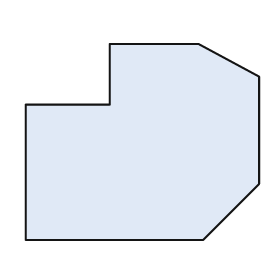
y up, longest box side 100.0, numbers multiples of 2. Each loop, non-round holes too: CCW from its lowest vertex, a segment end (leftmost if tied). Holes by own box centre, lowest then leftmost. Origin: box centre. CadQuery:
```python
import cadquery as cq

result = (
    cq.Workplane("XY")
    .moveTo(-50.0, -42.0)
    .lineTo(26.0, -42.0)
    .lineTo(50.0, -18.0)
    .lineTo(50.0, 28.0)
    .lineTo(24.0, 42.0)
    .lineTo(-14.0, 42.0)
    .lineTo(-14.0, 16.0)
    .lineTo(-50.0, 16.0)
    .close()
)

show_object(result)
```